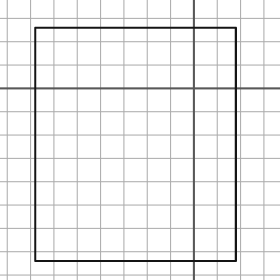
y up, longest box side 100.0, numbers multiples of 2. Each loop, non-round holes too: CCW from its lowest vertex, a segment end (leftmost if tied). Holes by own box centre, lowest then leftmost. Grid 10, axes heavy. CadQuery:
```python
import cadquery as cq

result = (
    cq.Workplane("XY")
    .moveTo(-68.0, -74.0)
    .lineTo(18.0, -74.0)
    .lineTo(18.0, 26.0)
    .lineTo(-68.0, 26.0)
    .close()
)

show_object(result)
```